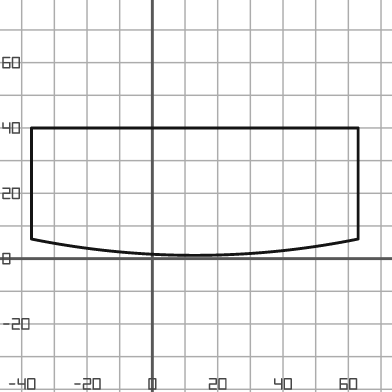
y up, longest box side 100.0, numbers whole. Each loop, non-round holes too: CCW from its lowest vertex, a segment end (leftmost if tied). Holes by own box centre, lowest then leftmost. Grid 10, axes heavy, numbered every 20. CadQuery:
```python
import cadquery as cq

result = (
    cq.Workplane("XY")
    .moveTo(-37.0, 6.0)
    .threePointArc((13.0, 1.0), (63.0, 6.0))
    .lineTo(63.0, 40.0)
    .lineTo(-37.0, 40.0)
    .close()
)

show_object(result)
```